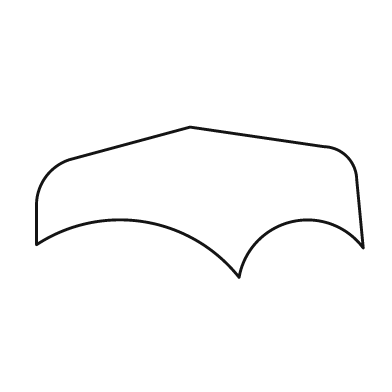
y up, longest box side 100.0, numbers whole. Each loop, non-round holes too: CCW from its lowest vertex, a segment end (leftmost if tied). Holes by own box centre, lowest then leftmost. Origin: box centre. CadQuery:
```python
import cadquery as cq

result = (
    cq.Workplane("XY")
    .moveTo(12.0, -23.0)
    .threePointArc((28.0, -6.0), (50.0, -14.0))
    .lineTo(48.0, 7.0)
    .threePointArc((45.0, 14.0), (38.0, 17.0))
    .lineTo(-3.0, 23.0)
    .lineTo(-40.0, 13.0)
    .threePointArc((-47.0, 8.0), (-50.0, 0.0))
    .lineTo(-50.0, -13.0)
    .threePointArc((-17.0, -6.0), (12.0, -23.0))
    .close()
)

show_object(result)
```